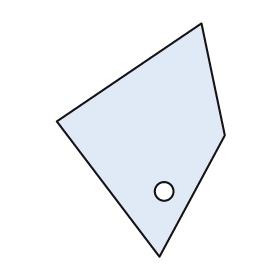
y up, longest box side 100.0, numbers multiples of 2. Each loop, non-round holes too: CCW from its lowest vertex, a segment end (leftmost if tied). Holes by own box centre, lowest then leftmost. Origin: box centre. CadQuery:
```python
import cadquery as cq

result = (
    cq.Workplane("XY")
    .moveTo(8.0, -50.0)
    .lineTo(36.0, 2.0)
    .lineTo(26.0, 50.0)
    .lineTo(-36.0, 8.0)
    .close()
    .moveTo(10.0, -22.0)
    .circle(4.0)
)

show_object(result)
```